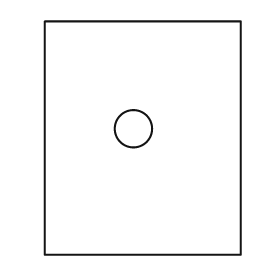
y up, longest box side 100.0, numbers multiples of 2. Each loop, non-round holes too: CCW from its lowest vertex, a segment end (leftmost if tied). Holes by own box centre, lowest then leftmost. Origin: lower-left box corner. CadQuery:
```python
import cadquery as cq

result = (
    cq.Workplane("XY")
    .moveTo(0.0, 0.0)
    .lineTo(84.0, 0.0)
    .lineTo(84.0, 100.0)
    .lineTo(0.0, 100.0)
    .close()
    .moveTo(38.0, 54.0)
    .circle(8.0)
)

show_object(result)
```